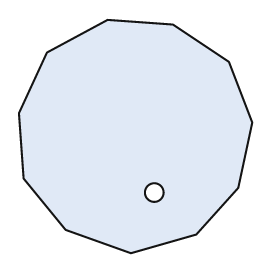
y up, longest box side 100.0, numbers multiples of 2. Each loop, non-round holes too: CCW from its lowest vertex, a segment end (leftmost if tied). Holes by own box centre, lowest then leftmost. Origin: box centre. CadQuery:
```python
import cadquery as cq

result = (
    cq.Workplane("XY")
    .moveTo(-2.0, -50.0)
    .lineTo(26.0, -42.0)
    .lineTo(44.0, -22.0)
    .lineTo(50.0, 6.0)
    .lineTo(40.0, 32.0)
    .lineTo(16.0, 48.0)
    .lineTo(-12.0, 50.0)
    .lineTo(-38.0, 36.0)
    .lineTo(-50.0, 10.0)
    .lineTo(-48.0, -18.0)
    .lineTo(-30.0, -40.0)
    .close()
    .moveTo(8.0, -24.0)
    .circle(4.0)
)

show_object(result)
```